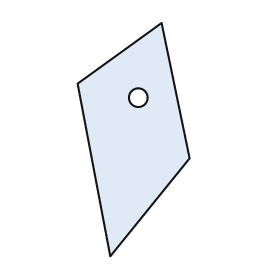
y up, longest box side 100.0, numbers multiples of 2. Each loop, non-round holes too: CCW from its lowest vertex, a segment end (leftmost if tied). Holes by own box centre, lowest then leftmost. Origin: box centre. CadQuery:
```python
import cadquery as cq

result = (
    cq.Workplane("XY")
    .moveTo(-10.0, -50.0)
    .lineTo(24.0, -8.0)
    .lineTo(12.0, 50.0)
    .lineTo(-24.0, 24.0)
    .close()
    .moveTo(2.0, 18.0)
    .circle(4.0)
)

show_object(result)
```